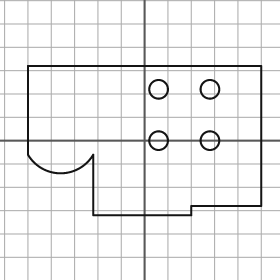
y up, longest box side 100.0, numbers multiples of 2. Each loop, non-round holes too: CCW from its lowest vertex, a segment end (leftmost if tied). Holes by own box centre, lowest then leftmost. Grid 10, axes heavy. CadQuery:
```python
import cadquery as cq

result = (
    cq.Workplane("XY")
    .moveTo(-22.0, -32.0)
    .lineTo(20.0, -32.0)
    .lineTo(20.0, -28.0)
    .lineTo(50.0, -28.0)
    .lineTo(50.0, 32.0)
    .lineTo(-50.0, 32.0)
    .lineTo(-50.0, -6.0)
    .threePointArc((-36.0, -14.0), (-22.0, -6.0))
    .close()
    .moveTo(6.0, 0.0)
    .circle(4.0)
    .moveTo(28.0, 0.0)
    .circle(4.0)
    .moveTo(6.0, 22.0)
    .circle(4.0)
    .moveTo(28.0, 22.0)
    .circle(4.0)
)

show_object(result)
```